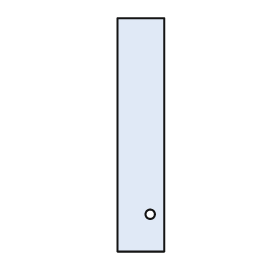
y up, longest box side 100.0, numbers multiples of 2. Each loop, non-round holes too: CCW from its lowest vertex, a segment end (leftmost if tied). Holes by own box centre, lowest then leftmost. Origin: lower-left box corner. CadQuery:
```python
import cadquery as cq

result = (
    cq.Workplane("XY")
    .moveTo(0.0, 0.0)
    .lineTo(20.0, 0.0)
    .lineTo(20.0, 100.0)
    .lineTo(0.0, 100.0)
    .close()
    .moveTo(14.0, 16.0)
    .circle(2.0)
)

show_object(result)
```